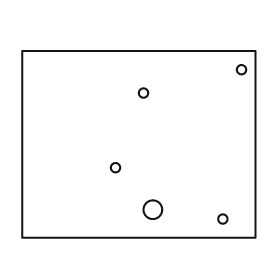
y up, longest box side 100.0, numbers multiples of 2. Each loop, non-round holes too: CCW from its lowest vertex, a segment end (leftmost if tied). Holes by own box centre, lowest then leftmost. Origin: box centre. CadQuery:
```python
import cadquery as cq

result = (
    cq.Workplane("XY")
    .moveTo(-50.0, -40.0)
    .lineTo(50.0, -40.0)
    .lineTo(50.0, 40.0)
    .lineTo(-50.0, 40.0)
    .close()
    .moveTo(36.0, -32.0)
    .circle(2.0)
    .moveTo(6.0, -28.0)
    .circle(4.0)
    .moveTo(-10.0, -10.0)
    .circle(2.0)
    .moveTo(2.0, 22.0)
    .circle(2.0)
    .moveTo(44.0, 32.0)
    .circle(2.0)
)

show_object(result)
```